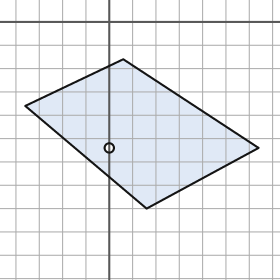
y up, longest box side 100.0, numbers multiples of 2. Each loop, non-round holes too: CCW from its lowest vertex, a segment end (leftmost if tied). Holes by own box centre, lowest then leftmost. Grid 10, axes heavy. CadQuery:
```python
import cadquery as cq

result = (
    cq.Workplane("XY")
    .moveTo(16.0, -80.0)
    .lineTo(64.0, -54.0)
    .lineTo(6.0, -16.0)
    .lineTo(-36.0, -36.0)
    .close()
    .moveTo(0.0, -54.0)
    .circle(2.0)
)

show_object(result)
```